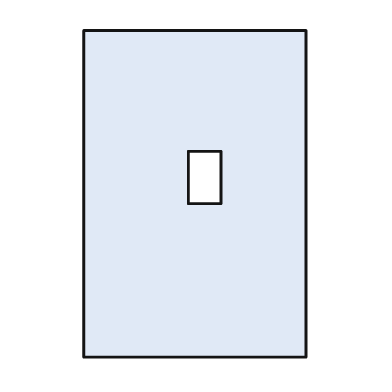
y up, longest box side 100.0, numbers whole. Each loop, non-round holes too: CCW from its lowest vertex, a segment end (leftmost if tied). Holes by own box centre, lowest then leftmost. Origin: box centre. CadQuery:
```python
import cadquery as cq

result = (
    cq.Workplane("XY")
    .moveTo(-34.0, -50.0)
    .lineTo(34.0, -50.0)
    .lineTo(34.0, 50.0)
    .lineTo(-34.0, 50.0)
    .close()
    .moveTo(-2.0, -3.0)
    .lineTo(8.0, -3.0)
    .lineTo(8.0, 13.0)
    .lineTo(-2.0, 13.0)
    .close()
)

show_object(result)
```